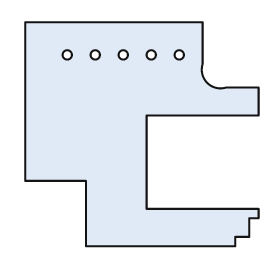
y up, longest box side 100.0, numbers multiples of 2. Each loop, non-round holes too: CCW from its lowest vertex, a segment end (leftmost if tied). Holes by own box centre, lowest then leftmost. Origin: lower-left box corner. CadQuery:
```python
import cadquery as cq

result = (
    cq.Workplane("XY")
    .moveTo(26.0, 0.0)
    .lineTo(90.0, 0.0)
    .lineTo(90.0, 4.0)
    .lineTo(96.0, 4.0)
    .lineTo(96.0, 12.0)
    .lineTo(100.0, 12.0)
    .lineTo(100.0, 16.0)
    .lineTo(52.0, 16.0)
    .lineTo(52.0, 56.0)
    .lineTo(100.0, 56.0)
    .lineTo(100.0, 68.0)
    .lineTo(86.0, 68.0)
    .threePointArc((78.0, 70.0), (76.0, 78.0))
    .lineTo(76.0, 96.0)
    .lineTo(0.0, 96.0)
    .lineTo(0.0, 28.0)
    .lineTo(26.0, 28.0)
    .close()
    .moveTo(18.0, 82.0)
    .circle(2.0)
    .moveTo(30.0, 82.0)
    .circle(2.0)
    .moveTo(42.0, 82.0)
    .circle(2.0)
    .moveTo(54.0, 82.0)
    .circle(2.0)
    .moveTo(66.0, 82.0)
    .circle(2.0)
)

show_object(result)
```